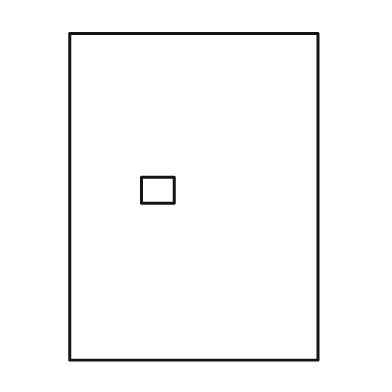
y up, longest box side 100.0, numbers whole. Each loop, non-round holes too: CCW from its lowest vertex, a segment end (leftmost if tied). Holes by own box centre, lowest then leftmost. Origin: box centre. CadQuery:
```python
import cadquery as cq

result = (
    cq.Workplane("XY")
    .moveTo(-38.0, -50.0)
    .lineTo(38.0, -50.0)
    .lineTo(38.0, 50.0)
    .lineTo(-38.0, 50.0)
    .close()
    .moveTo(-16.0, -2.0)
    .lineTo(-6.0, -2.0)
    .lineTo(-6.0, 6.0)
    .lineTo(-16.0, 6.0)
    .close()
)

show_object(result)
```